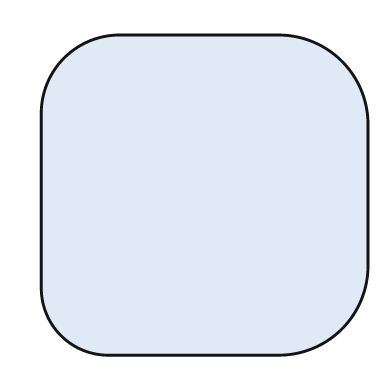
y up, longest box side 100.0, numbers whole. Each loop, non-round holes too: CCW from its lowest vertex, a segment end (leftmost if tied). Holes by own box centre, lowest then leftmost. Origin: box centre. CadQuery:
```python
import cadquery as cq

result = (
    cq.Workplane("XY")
    .moveTo(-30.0, -49.0)
    .lineTo(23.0, -49.0)
    .threePointArc((42.0, -41.0), (50.0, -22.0))
    .lineTo(50.0, 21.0)
    .threePointArc((42.0, 41.0), (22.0, 49.0))
    .lineTo(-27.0, 49.0)
    .threePointArc((-43.0, 42.0), (-50.0, 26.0))
    .lineTo(-50.0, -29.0)
    .threePointArc((-44.0, -43.0), (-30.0, -49.0))
    .close()
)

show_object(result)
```